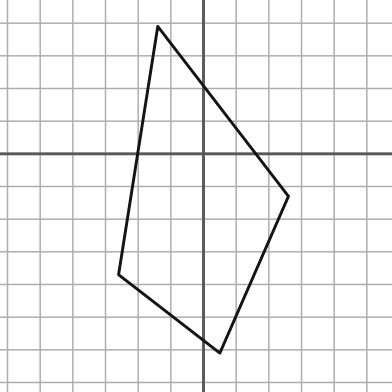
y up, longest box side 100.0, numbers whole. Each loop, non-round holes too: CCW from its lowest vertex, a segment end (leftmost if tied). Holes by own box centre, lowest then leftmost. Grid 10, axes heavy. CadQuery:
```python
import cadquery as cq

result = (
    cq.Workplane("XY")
    .moveTo(5.0, -61.0)
    .lineTo(26.0, -13.0)
    .lineTo(-14.0, 39.0)
    .lineTo(-26.0, -37.0)
    .close()
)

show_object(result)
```